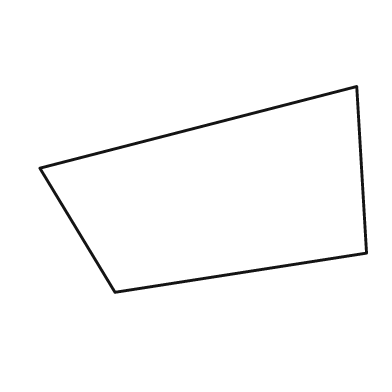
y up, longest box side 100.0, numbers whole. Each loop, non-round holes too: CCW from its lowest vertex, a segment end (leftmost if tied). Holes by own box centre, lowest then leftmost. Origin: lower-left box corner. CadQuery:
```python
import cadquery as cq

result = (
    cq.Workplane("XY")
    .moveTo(23.0, 0.0)
    .lineTo(100.0, 12.0)
    .lineTo(97.0, 63.0)
    .lineTo(0.0, 38.0)
    .close()
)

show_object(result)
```